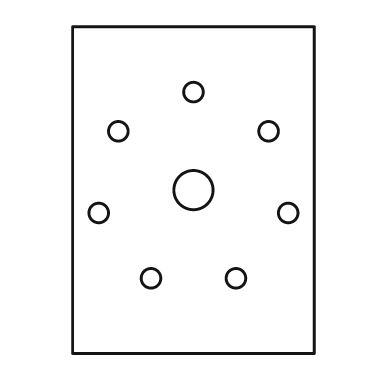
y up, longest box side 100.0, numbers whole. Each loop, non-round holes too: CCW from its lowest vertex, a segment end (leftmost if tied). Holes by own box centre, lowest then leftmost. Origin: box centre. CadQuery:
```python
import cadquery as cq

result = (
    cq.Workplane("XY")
    .moveTo(-37.0, -50.0)
    .lineTo(37.0, -50.0)
    .lineTo(37.0, 50.0)
    .lineTo(-37.0, 50.0)
    .close()
    .moveTo(-13.0, -27.0)
    .circle(3.0)
    .moveTo(13.0, -27.0)
    .circle(3.0)
    .moveTo(-29.0, -7.0)
    .circle(3.0)
    .moveTo(29.0, -7.0)
    .circle(3.0)
    .moveTo(0.0, 0.0)
    .circle(6.0)
    .moveTo(-23.0, 18.0)
    .circle(3.0)
    .moveTo(23.0, 18.0)
    .circle(3.0)
    .moveTo(0.0, 30.0)
    .circle(3.0)
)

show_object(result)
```